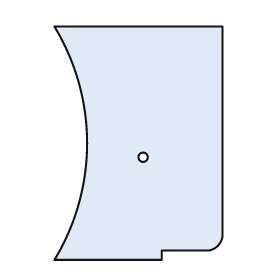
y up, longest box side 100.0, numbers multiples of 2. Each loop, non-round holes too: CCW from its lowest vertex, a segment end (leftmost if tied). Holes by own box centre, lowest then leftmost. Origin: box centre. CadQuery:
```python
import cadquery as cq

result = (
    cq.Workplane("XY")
    .moveTo(-36.0, -50.0)
    .lineTo(10.0, -50.0)
    .lineTo(10.0, -46.0)
    .lineTo(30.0, -46.0)
    .threePointArc((34.0, -44.0), (36.0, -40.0))
    .lineTo(36.0, 50.0)
    .lineTo(-36.0, 50.0)
    .threePointArc((-22.0, 0.0), (-36.0, -50.0))
    .close()
    .moveTo(2.0, -6.0)
    .circle(2.0)
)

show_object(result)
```